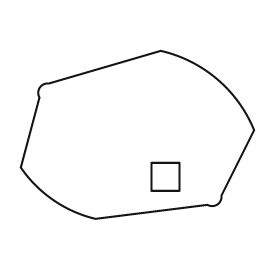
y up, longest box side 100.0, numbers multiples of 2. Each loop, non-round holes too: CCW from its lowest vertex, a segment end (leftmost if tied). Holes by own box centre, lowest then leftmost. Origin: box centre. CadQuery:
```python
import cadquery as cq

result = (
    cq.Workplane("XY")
    .moveTo(-18.0, -36.0)
    .lineTo(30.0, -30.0)
    .threePointArc((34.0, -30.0), (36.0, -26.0))
    .lineTo(50.0, 2.0)
    .threePointArc((34.0, 24.0), (10.0, 36.0))
    .lineTo(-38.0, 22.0)
    .threePointArc((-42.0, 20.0), (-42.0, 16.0))
    .lineTo(-50.0, -14.0)
    .threePointArc((-36.0, -28.0), (-18.0, -36.0))
    .close()
    .moveTo(6.0, -24.0)
    .lineTo(18.0, -24.0)
    .lineTo(18.0, -12.0)
    .lineTo(6.0, -12.0)
    .close()
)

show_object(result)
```